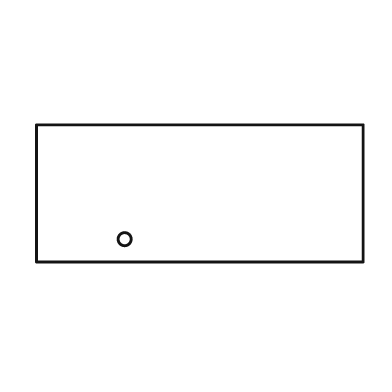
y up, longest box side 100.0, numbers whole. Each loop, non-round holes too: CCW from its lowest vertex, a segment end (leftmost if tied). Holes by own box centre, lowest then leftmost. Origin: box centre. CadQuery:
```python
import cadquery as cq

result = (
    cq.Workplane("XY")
    .moveTo(-50.0, -21.0)
    .lineTo(50.0, -21.0)
    .lineTo(50.0, 21.0)
    .lineTo(-50.0, 21.0)
    .close()
    .moveTo(-23.0, -14.0)
    .circle(2.0)
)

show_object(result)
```